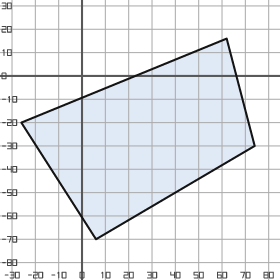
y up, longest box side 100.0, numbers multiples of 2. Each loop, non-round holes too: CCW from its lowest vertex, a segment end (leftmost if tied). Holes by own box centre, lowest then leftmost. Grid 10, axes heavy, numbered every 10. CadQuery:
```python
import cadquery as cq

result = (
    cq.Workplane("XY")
    .moveTo(6.0, -70.0)
    .lineTo(74.0, -30.0)
    .lineTo(62.0, 16.0)
    .lineTo(-26.0, -20.0)
    .close()
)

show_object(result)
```